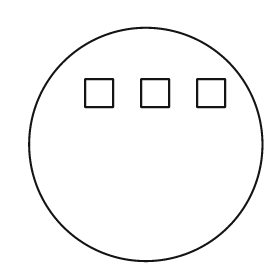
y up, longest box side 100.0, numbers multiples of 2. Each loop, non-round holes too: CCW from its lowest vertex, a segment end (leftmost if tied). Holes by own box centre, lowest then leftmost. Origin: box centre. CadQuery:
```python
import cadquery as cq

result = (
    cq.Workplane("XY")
    .moveTo(0.0, 0.0)
    .circle(50.0)
    .moveTo(-26.0, 16.0)
    .lineTo(-14.0, 16.0)
    .lineTo(-14.0, 28.0)
    .lineTo(-26.0, 28.0)
    .close()
    .moveTo(-2.0, 16.0)
    .lineTo(10.0, 16.0)
    .lineTo(10.0, 28.0)
    .lineTo(-2.0, 28.0)
    .close()
    .moveTo(22.0, 16.0)
    .lineTo(34.0, 16.0)
    .lineTo(34.0, 28.0)
    .lineTo(22.0, 28.0)
    .close()
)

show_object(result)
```